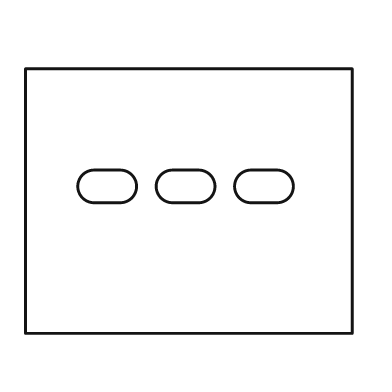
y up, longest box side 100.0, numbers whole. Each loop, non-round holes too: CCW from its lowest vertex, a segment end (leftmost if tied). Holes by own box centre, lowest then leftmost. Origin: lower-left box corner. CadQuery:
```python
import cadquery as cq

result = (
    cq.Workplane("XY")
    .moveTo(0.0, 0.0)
    .lineTo(100.0, 0.0)
    .lineTo(100.0, 81.0)
    .lineTo(0.0, 81.0)
    .close()
    .moveTo(21.0, 40.0)
    .lineTo(29.0, 40.0)
    .threePointArc((34.0, 45.0), (29.0, 50.0))
    .lineTo(21.0, 50.0)
    .threePointArc((16.0, 45.0), (21.0, 40.0))
    .close()
    .moveTo(45.0, 40.0)
    .lineTo(53.0, 40.0)
    .threePointArc((58.0, 45.0), (53.0, 50.0))
    .lineTo(45.0, 50.0)
    .threePointArc((40.0, 45.0), (45.0, 40.0))
    .close()
    .moveTo(69.0, 40.0)
    .lineTo(77.0, 40.0)
    .threePointArc((82.0, 45.0), (77.0, 50.0))
    .lineTo(69.0, 50.0)
    .threePointArc((64.0, 45.0), (69.0, 40.0))
    .close()
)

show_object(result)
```